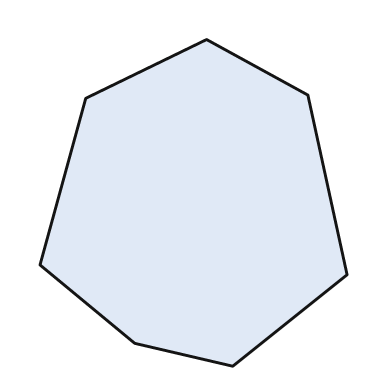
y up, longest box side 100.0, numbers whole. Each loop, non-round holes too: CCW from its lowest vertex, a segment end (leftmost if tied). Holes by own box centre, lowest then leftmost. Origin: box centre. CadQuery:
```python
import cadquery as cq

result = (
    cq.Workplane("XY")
    .moveTo(12.0, -50.0)
    .lineTo(47.0, -22.0)
    .lineTo(35.0, 33.0)
    .lineTo(4.0, 50.0)
    .lineTo(-33.0, 32.0)
    .lineTo(-47.0, -19.0)
    .lineTo(-18.0, -43.0)
    .close()
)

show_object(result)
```